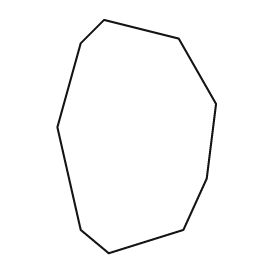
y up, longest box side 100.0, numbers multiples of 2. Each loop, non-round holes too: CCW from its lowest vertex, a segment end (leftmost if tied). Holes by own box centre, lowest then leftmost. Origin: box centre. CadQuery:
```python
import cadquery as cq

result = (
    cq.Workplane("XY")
    .moveTo(-12.0, -50.0)
    .lineTo(20.0, -40.0)
    .lineTo(30.0, -18.0)
    .lineTo(34.0, 14.0)
    .lineTo(18.0, 42.0)
    .lineTo(-14.0, 50.0)
    .lineTo(-24.0, 40.0)
    .lineTo(-34.0, 4.0)
    .lineTo(-24.0, -40.0)
    .close()
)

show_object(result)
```